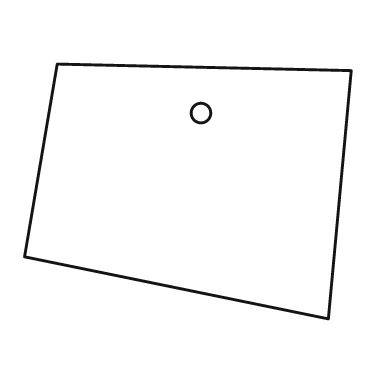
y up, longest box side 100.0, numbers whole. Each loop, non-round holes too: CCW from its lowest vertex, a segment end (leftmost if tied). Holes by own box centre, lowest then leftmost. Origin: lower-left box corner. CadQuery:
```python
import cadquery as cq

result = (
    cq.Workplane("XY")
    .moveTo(93.0, 0.0)
    .lineTo(100.0, 76.0)
    .lineTo(10.0, 78.0)
    .lineTo(0.0, 19.0)
    .close()
    .moveTo(54.0, 63.0)
    .circle(3.0)
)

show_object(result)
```